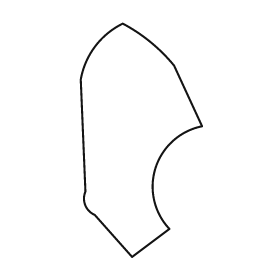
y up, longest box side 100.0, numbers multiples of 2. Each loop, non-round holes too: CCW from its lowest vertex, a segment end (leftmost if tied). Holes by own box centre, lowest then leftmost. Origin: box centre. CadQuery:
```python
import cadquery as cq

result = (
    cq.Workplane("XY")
    .moveTo(-4.0, -50.0)
    .lineTo(12.0, -38.0)
    .threePointArc((6.0, -12.0), (26.0, 6.0))
    .lineTo(14.0, 32.0)
    .threePointArc((4.0, 42.0), (-8.0, 50.0))
    .threePointArc((-20.0, 40.0), (-26.0, 26.0))
    .lineTo(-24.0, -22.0)
    .threePointArc((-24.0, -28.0), (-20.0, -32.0))
    .close()
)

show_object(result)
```